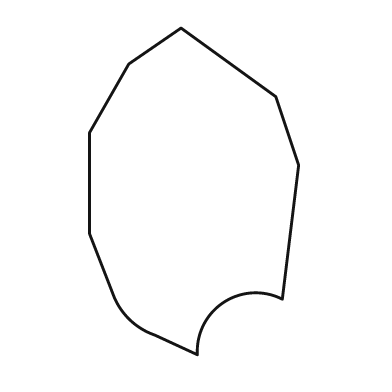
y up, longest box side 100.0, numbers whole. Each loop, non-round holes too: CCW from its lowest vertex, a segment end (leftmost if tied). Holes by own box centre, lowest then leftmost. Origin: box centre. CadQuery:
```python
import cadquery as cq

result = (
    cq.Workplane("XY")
    .moveTo(1.0, -50.0)
    .threePointArc((9.0, -34.0), (27.0, -33.0))
    .lineTo(32.0, 8.0)
    .lineTo(25.0, 29.0)
    .lineTo(-4.0, 50.0)
    .lineTo(-20.0, 39.0)
    .lineTo(-32.0, 18.0)
    .lineTo(-32.0, -13.0)
    .lineTo(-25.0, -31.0)
    .threePointArc((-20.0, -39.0), (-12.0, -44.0))
    .close()
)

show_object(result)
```